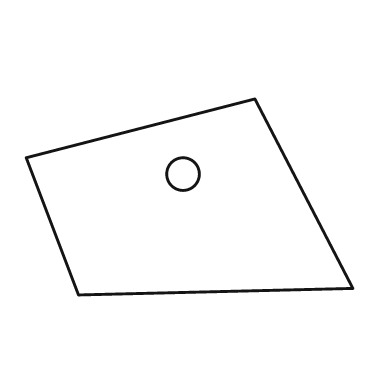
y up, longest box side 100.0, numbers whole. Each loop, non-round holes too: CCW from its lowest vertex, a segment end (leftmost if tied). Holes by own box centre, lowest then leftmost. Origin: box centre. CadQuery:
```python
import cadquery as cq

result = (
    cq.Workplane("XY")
    .moveTo(-34.0, -30.0)
    .lineTo(50.0, -28.0)
    .lineTo(20.0, 30.0)
    .lineTo(-50.0, 12.0)
    .close()
    .moveTo(-2.0, 7.0)
    .circle(5.0)
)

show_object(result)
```